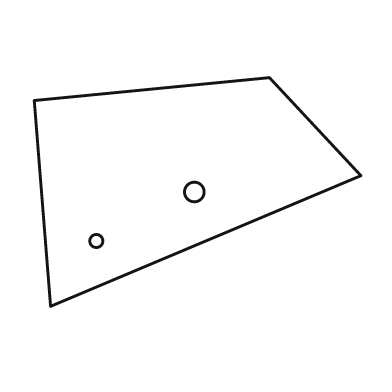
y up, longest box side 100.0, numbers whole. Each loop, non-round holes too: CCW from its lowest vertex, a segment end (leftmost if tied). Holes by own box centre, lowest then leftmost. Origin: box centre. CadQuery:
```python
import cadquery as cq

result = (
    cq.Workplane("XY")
    .moveTo(-45.0, -35.0)
    .lineTo(50.0, 5.0)
    .lineTo(22.0, 35.0)
    .lineTo(-50.0, 28.0)
    .close()
    .moveTo(-31.0, -15.0)
    .circle(2.0)
    .moveTo(-1.0, 0.0)
    .circle(3.0)
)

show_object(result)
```